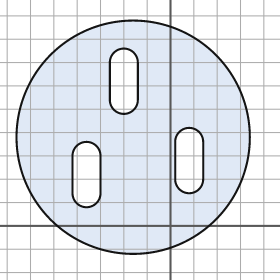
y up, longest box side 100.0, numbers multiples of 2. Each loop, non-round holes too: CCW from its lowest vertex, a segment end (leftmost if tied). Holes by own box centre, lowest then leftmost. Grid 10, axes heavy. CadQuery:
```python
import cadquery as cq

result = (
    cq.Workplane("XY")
    .moveTo(-16.0, 38.0)
    .circle(50.0)
    .moveTo(-42.0, 14.0)
    .threePointArc((-36.0, 8.0), (-30.0, 14.0))
    .lineTo(-30.0, 30.0)
    .threePointArc((-36.0, 36.0), (-42.0, 30.0))
    .close()
    .moveTo(2.0, 20.0)
    .threePointArc((8.0, 14.0), (14.0, 20.0))
    .lineTo(14.0, 36.0)
    .threePointArc((8.0, 42.0), (2.0, 36.0))
    .close()
    .moveTo(-26.0, 54.0)
    .threePointArc((-20.0, 48.0), (-14.0, 54.0))
    .lineTo(-14.0, 70.0)
    .threePointArc((-20.0, 76.0), (-26.0, 70.0))
    .close()
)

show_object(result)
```